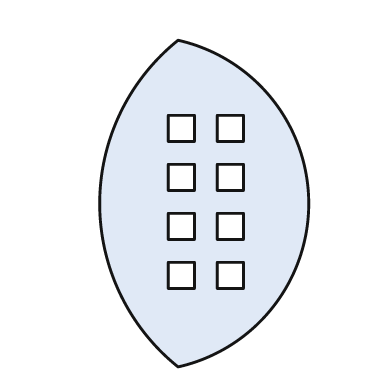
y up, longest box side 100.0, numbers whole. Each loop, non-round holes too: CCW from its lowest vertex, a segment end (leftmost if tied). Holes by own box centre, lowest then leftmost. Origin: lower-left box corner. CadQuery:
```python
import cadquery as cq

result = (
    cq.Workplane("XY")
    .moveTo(24.0, 0.0)
    .threePointArc((64.0, 50.0), (24.0, 100.0))
    .threePointArc((0.0, 50.0), (24.0, 0.0))
    .close()
    .moveTo(21.0, 24.0)
    .lineTo(29.0, 24.0)
    .lineTo(29.0, 32.0)
    .lineTo(21.0, 32.0)
    .close()
    .moveTo(36.0, 24.0)
    .lineTo(44.0, 24.0)
    .lineTo(44.0, 32.0)
    .lineTo(36.0, 32.0)
    .close()
    .moveTo(21.0, 39.0)
    .lineTo(29.0, 39.0)
    .lineTo(29.0, 47.0)
    .lineTo(21.0, 47.0)
    .close()
    .moveTo(36.0, 39.0)
    .lineTo(44.0, 39.0)
    .lineTo(44.0, 47.0)
    .lineTo(36.0, 47.0)
    .close()
    .moveTo(21.0, 54.0)
    .lineTo(29.0, 54.0)
    .lineTo(29.0, 62.0)
    .lineTo(21.0, 62.0)
    .close()
    .moveTo(36.0, 54.0)
    .lineTo(44.0, 54.0)
    .lineTo(44.0, 62.0)
    .lineTo(36.0, 62.0)
    .close()
    .moveTo(21.0, 69.0)
    .lineTo(29.0, 69.0)
    .lineTo(29.0, 77.0)
    .lineTo(21.0, 77.0)
    .close()
    .moveTo(36.0, 69.0)
    .lineTo(44.0, 69.0)
    .lineTo(44.0, 77.0)
    .lineTo(36.0, 77.0)
    .close()
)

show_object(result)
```